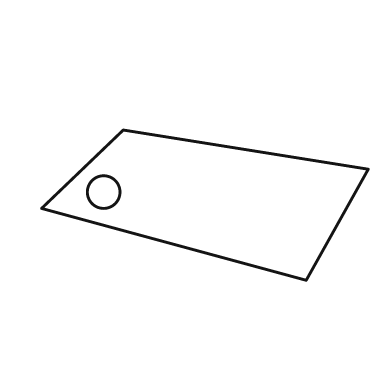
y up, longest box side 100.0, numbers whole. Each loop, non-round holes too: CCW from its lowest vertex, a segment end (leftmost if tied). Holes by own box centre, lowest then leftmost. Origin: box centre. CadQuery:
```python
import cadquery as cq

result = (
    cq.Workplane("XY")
    .moveTo(31.0, -23.0)
    .lineTo(50.0, 11.0)
    .lineTo(-25.0, 23.0)
    .lineTo(-50.0, -1.0)
    .close()
    .moveTo(-31.0, 4.0)
    .circle(5.0)
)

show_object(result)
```